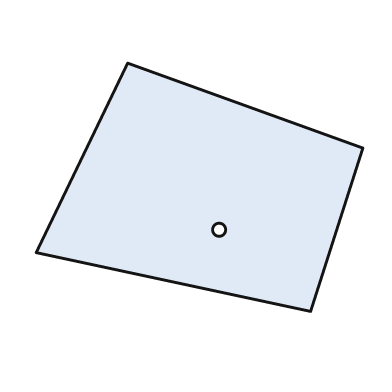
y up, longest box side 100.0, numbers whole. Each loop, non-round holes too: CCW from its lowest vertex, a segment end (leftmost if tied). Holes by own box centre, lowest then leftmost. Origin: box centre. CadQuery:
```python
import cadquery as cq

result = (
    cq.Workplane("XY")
    .moveTo(34.0, -38.0)
    .lineTo(50.0, 12.0)
    .lineTo(-22.0, 38.0)
    .lineTo(-50.0, -20.0)
    .close()
    .moveTo(6.0, -13.0)
    .circle(2.0)
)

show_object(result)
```